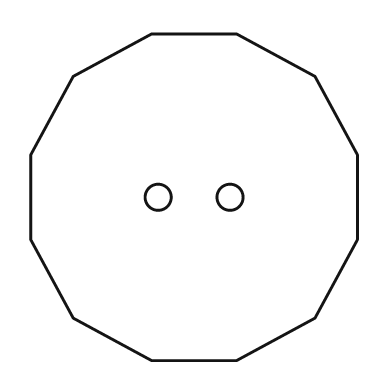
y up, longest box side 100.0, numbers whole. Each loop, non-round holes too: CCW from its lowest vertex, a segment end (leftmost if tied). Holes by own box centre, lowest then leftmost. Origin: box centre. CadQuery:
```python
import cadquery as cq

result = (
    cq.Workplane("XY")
    .moveTo(-13.0, -50.0)
    .lineTo(13.0, -50.0)
    .lineTo(37.0, -37.0)
    .lineTo(50.0, -13.0)
    .lineTo(50.0, 13.0)
    .lineTo(37.0, 37.0)
    .lineTo(13.0, 50.0)
    .lineTo(-13.0, 50.0)
    .lineTo(-37.0, 37.0)
    .lineTo(-50.0, 13.0)
    .lineTo(-50.0, -13.0)
    .lineTo(-37.0, -37.0)
    .close()
    .moveTo(-11.0, 0.0)
    .circle(4.0)
    .moveTo(11.0, 0.0)
    .circle(4.0)
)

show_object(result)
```